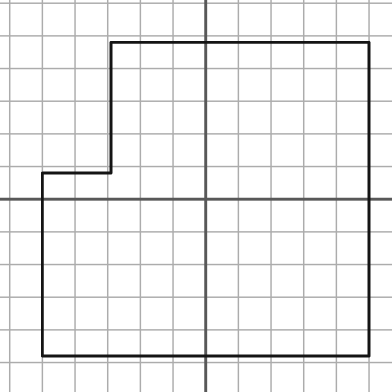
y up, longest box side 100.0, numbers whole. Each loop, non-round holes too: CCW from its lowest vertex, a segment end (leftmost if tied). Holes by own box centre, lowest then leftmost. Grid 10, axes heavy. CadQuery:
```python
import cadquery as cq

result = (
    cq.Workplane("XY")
    .moveTo(-50.0, -48.0)
    .lineTo(50.0, -48.0)
    .lineTo(50.0, 48.0)
    .lineTo(-29.0, 48.0)
    .lineTo(-29.0, 8.0)
    .lineTo(-50.0, 8.0)
    .close()
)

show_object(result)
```